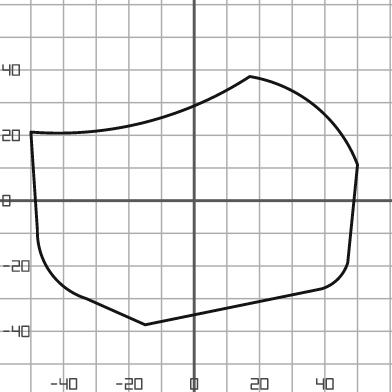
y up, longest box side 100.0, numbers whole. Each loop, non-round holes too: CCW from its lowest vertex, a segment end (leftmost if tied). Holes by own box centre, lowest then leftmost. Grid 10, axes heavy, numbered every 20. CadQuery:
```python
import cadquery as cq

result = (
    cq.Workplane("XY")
    .moveTo(-15.0, -38.0)
    .lineTo(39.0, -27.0)
    .threePointArc((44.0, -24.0), (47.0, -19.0))
    .lineTo(50.0, 11.0)
    .threePointArc((37.0, 29.0), (17.0, 38.0))
    .threePointArc((-15.0, 24.0), (-50.0, 21.0))
    .lineTo(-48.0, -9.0)
    .threePointArc((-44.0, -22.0), (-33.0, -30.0))
    .close()
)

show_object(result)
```